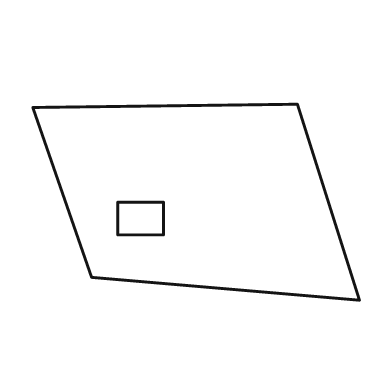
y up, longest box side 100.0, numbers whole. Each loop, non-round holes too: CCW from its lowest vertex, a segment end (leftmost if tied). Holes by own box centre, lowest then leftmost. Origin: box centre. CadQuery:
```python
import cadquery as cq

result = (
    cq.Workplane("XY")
    .moveTo(50.0, -30.0)
    .lineTo(31.0, 30.0)
    .lineTo(-50.0, 29.0)
    .lineTo(-32.0, -23.0)
    .close()
    .moveTo(-24.0, -10.0)
    .lineTo(-10.0, -10.0)
    .lineTo(-10.0, 0.0)
    .lineTo(-24.0, 0.0)
    .close()
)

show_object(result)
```